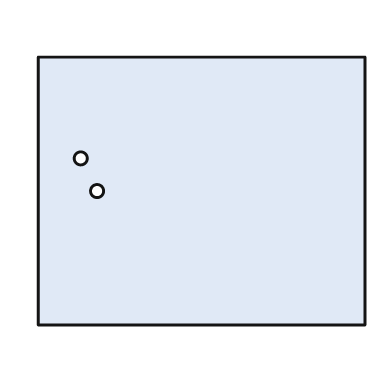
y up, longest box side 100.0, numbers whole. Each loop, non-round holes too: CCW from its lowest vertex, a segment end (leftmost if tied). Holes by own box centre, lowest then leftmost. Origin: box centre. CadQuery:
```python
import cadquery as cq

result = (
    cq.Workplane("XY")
    .moveTo(-50.0, -41.0)
    .lineTo(50.0, -41.0)
    .lineTo(50.0, 41.0)
    .lineTo(-50.0, 41.0)
    .close()
    .moveTo(-32.0, 0.0)
    .circle(2.0)
    .moveTo(-37.0, 10.0)
    .circle(2.0)
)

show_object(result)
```